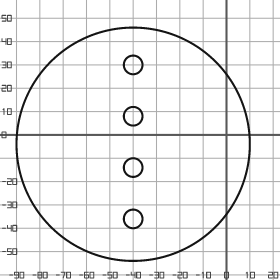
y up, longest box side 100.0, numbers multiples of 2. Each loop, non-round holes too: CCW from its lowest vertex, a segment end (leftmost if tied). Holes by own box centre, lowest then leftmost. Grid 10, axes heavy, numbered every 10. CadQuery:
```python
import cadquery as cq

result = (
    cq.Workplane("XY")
    .moveTo(-40.0, -4.0)
    .circle(50.0)
    .moveTo(-40.0, -36.0)
    .circle(4.0)
    .moveTo(-40.0, -14.0)
    .circle(4.0)
    .moveTo(-40.0, 8.0)
    .circle(4.0)
    .moveTo(-40.0, 30.0)
    .circle(4.0)
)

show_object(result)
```